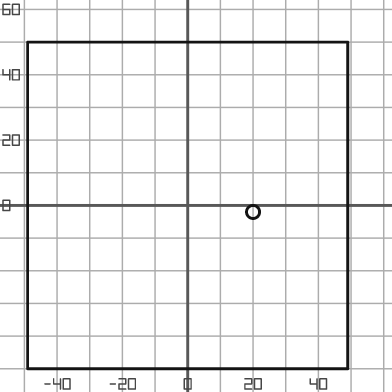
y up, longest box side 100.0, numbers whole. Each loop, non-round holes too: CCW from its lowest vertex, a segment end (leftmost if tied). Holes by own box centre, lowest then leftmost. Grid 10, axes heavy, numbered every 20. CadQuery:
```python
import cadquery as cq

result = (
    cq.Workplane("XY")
    .moveTo(-49.0, -50.0)
    .lineTo(49.0, -50.0)
    .lineTo(49.0, 50.0)
    .lineTo(-49.0, 50.0)
    .close()
    .moveTo(20.0, -2.0)
    .circle(2.0)
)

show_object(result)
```